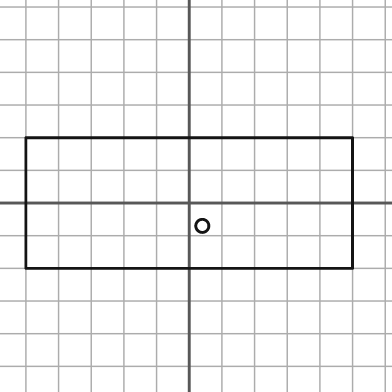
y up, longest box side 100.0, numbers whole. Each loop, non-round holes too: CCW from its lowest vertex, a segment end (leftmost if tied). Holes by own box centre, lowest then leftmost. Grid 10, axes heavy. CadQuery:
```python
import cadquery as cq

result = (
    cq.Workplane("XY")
    .moveTo(-50.0, -20.0)
    .lineTo(50.0, -20.0)
    .lineTo(50.0, 20.0)
    .lineTo(-50.0, 20.0)
    .close()
    .moveTo(4.0, -7.0)
    .circle(2.0)
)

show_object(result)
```